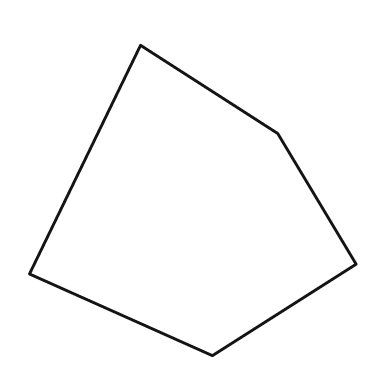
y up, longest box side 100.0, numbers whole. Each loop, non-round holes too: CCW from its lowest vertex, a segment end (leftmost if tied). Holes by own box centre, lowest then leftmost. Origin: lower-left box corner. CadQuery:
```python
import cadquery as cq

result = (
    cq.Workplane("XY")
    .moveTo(56.0, 0.0)
    .lineTo(100.0, 28.0)
    .lineTo(76.0, 68.0)
    .lineTo(34.0, 95.0)
    .lineTo(0.0, 25.0)
    .close()
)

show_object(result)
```